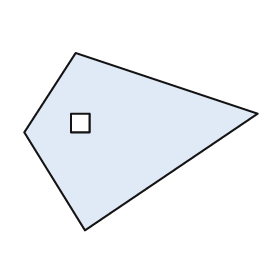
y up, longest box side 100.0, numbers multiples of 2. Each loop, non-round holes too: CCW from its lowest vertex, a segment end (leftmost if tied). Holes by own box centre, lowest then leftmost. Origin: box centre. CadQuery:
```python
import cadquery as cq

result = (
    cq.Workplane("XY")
    .moveTo(-24.0, -38.0)
    .lineTo(50.0, 12.0)
    .lineTo(-28.0, 38.0)
    .lineTo(-50.0, 4.0)
    .close()
    .moveTo(-30.0, 4.0)
    .lineTo(-22.0, 4.0)
    .lineTo(-22.0, 12.0)
    .lineTo(-30.0, 12.0)
    .close()
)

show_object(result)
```